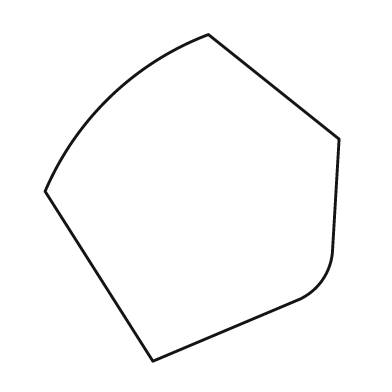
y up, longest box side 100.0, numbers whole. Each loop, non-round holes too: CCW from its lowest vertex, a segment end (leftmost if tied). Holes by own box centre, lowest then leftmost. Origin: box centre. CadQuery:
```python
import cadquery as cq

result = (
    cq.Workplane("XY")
    .moveTo(-12.0, -50.0)
    .lineTo(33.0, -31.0)
    .threePointArc((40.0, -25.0), (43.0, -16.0))
    .lineTo(45.0, 18.0)
    .lineTo(5.0, 50.0)
    .threePointArc((-25.0, 31.0), (-45.0, 2.0))
    .close()
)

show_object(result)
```